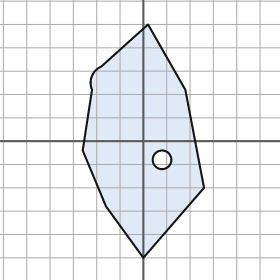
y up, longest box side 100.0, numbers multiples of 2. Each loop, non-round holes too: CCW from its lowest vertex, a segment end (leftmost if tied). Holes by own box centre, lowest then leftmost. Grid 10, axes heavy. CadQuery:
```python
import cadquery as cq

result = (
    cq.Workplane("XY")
    .moveTo(0.0, -50.0)
    .lineTo(26.0, -20.0)
    .lineTo(18.0, 22.0)
    .lineTo(2.0, 50.0)
    .lineTo(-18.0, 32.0)
    .threePointArc((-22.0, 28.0), (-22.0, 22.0))
    .lineTo(-26.0, -4.0)
    .lineTo(-16.0, -28.0)
    .close()
    .moveTo(8.0, -8.0)
    .circle(4.0)
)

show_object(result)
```